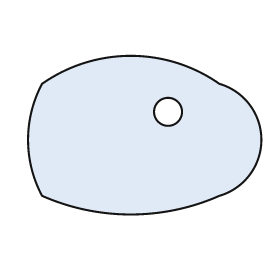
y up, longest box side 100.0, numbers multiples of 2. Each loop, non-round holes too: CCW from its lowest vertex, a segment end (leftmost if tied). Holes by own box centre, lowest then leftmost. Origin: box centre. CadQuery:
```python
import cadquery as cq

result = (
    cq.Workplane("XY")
    .moveTo(-44.0, -26.0)
    .threePointArc((-6.0, -34.0), (32.0, -26.0))
    .threePointArc((50.0, -2.0), (32.0, 22.0))
    .threePointArc((-6.0, 34.0), (-44.0, 22.0))
    .threePointArc((-50.0, -2.0), (-44.0, -26.0))
    .close()
    .moveTo(10.0, 10.0)
    .circle(6.0)
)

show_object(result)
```